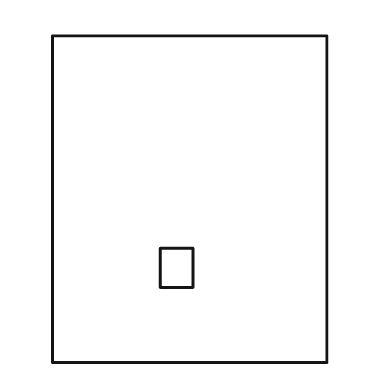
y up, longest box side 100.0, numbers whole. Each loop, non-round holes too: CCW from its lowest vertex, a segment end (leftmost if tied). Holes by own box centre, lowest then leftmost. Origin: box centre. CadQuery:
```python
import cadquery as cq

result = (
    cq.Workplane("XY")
    .moveTo(-42.0, -50.0)
    .lineTo(42.0, -50.0)
    .lineTo(42.0, 50.0)
    .lineTo(-42.0, 50.0)
    .close()
    .moveTo(-9.0, -27.0)
    .lineTo(1.0, -27.0)
    .lineTo(1.0, -15.0)
    .lineTo(-9.0, -15.0)
    .close()
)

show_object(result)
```